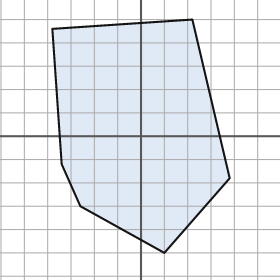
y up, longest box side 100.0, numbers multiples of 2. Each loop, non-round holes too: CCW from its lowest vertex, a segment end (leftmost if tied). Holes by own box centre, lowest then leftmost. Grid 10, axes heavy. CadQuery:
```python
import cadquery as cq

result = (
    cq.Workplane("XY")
    .moveTo(10.0, -50.0)
    .lineTo(38.0, -18.0)
    .lineTo(22.0, 50.0)
    .lineTo(-38.0, 46.0)
    .lineTo(-34.0, -12.0)
    .lineTo(-26.0, -30.0)
    .close()
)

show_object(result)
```